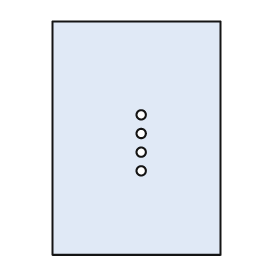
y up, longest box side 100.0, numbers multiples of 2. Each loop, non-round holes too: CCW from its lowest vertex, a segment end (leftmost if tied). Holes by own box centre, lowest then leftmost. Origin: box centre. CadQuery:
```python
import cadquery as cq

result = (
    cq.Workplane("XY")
    .moveTo(-36.0, -50.0)
    .lineTo(36.0, -50.0)
    .lineTo(36.0, 50.0)
    .lineTo(-36.0, 50.0)
    .close()
    .moveTo(2.0, -14.0)
    .circle(2.0)
    .moveTo(2.0, -6.0)
    .circle(2.0)
    .moveTo(2.0, 2.0)
    .circle(2.0)
    .moveTo(2.0, 10.0)
    .circle(2.0)
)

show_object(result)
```